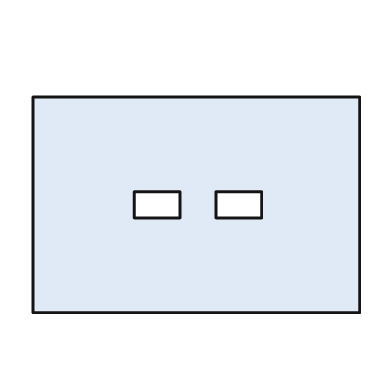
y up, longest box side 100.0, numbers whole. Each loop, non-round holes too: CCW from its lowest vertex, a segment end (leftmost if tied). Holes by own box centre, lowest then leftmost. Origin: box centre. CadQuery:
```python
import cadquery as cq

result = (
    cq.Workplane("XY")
    .moveTo(-50.0, -33.0)
    .lineTo(50.0, -33.0)
    .lineTo(50.0, 33.0)
    .lineTo(-50.0, 33.0)
    .close()
    .moveTo(-19.0, -4.0)
    .lineTo(-5.0, -4.0)
    .lineTo(-5.0, 4.0)
    .lineTo(-19.0, 4.0)
    .close()
    .moveTo(6.0, -4.0)
    .lineTo(20.0, -4.0)
    .lineTo(20.0, 4.0)
    .lineTo(6.0, 4.0)
    .close()
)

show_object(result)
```